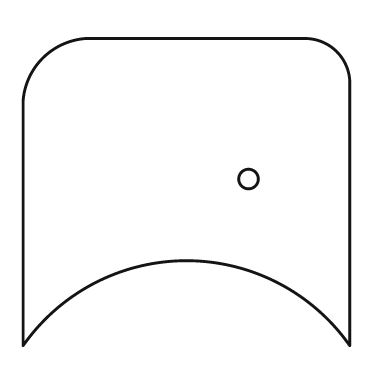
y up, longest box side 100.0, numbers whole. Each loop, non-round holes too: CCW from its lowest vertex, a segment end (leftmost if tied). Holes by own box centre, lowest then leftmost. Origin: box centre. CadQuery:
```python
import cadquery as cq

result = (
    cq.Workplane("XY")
    .moveTo(-50.0, -47.0)
    .threePointArc((0.0, -21.0), (50.0, -47.0))
    .lineTo(50.0, 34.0)
    .threePointArc((46.0, 43.0), (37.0, 47.0))
    .lineTo(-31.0, 47.0)
    .threePointArc((-44.0, 41.0), (-50.0, 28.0))
    .close()
    .moveTo(19.0, 4.0)
    .circle(3.0)
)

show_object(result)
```